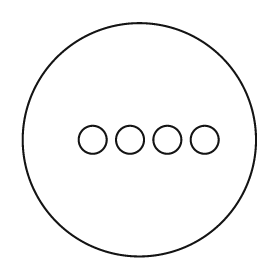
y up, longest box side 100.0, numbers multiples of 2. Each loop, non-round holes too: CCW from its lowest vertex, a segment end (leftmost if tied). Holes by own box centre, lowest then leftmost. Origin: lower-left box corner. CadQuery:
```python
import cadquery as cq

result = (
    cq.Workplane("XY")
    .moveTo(50.0, 50.0)
    .circle(50.0)
    .moveTo(30.0, 50.0)
    .circle(6.0)
    .moveTo(46.0, 50.0)
    .circle(6.0)
    .moveTo(62.0, 50.0)
    .circle(6.0)
    .moveTo(78.0, 50.0)
    .circle(6.0)
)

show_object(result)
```